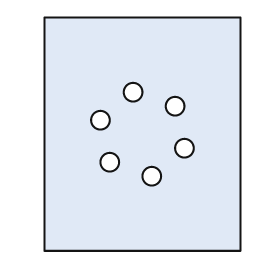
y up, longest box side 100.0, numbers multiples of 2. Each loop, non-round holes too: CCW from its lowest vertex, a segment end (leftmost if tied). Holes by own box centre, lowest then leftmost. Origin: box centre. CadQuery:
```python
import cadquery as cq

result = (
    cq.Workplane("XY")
    .moveTo(-42.0, -50.0)
    .lineTo(42.0, -50.0)
    .lineTo(42.0, 50.0)
    .lineTo(-42.0, 50.0)
    .close()
    .moveTo(4.0, -18.0)
    .circle(4.0)
    .moveTo(-14.0, -12.0)
    .circle(4.0)
    .moveTo(18.0, -6.0)
    .circle(4.0)
    .moveTo(-18.0, 6.0)
    .circle(4.0)
    .moveTo(14.0, 12.0)
    .circle(4.0)
    .moveTo(-4.0, 18.0)
    .circle(4.0)
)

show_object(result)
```